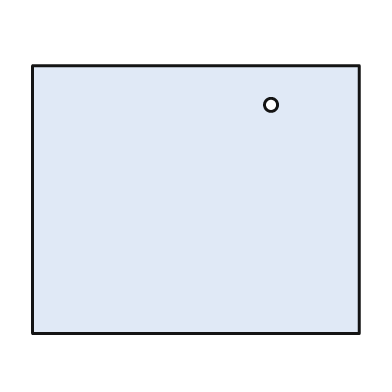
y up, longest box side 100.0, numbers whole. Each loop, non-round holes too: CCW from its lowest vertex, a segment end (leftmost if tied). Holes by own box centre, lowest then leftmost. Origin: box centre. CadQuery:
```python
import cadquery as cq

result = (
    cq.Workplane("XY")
    .moveTo(-50.0, -41.0)
    .lineTo(50.0, -41.0)
    .lineTo(50.0, 41.0)
    .lineTo(-50.0, 41.0)
    .close()
    .moveTo(23.0, 29.0)
    .circle(2.0)
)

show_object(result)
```